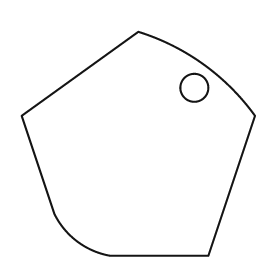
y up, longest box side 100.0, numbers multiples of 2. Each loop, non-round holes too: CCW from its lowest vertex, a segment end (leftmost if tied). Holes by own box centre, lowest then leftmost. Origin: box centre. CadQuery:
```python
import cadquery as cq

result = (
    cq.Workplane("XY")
    .moveTo(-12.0, -48.0)
    .lineTo(30.0, -48.0)
    .lineTo(50.0, 12.0)
    .threePointArc((28.0, 34.0), (0.0, 48.0))
    .lineTo(-50.0, 12.0)
    .lineTo(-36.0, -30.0)
    .threePointArc((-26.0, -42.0), (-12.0, -48.0))
    .close()
    .moveTo(24.0, 24.0)
    .circle(6.0)
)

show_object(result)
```